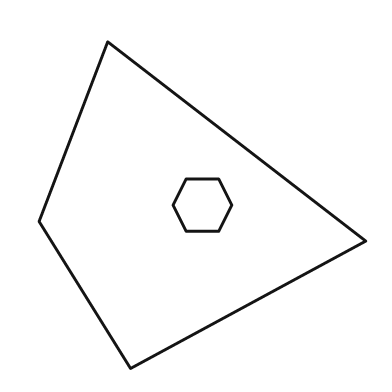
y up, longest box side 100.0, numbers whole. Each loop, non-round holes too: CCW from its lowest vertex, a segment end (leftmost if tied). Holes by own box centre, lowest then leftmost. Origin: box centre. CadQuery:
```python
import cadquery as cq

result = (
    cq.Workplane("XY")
    .moveTo(-22.0, -50.0)
    .lineTo(50.0, -11.0)
    .lineTo(-29.0, 50.0)
    .lineTo(-50.0, -5.0)
    .close()
    .moveTo(-5.0, -8.0)
    .lineTo(5.0, -8.0)
    .lineTo(9.0, 0.0)
    .lineTo(5.0, 8.0)
    .lineTo(-5.0, 8.0)
    .lineTo(-9.0, 0.0)
    .close()
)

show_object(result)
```